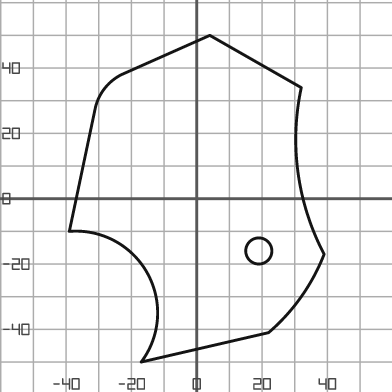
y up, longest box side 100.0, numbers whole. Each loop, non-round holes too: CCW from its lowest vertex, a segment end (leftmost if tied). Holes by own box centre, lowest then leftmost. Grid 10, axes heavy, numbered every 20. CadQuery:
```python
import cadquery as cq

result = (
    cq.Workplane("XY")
    .moveTo(-17.0, -50.0)
    .lineTo(22.0, -41.0)
    .threePointArc((32.0, -30.0), (39.0, -17.0))
    .threePointArc((31.0, 8.0), (32.0, 34.0))
    .lineTo(4.0, 50.0)
    .lineTo(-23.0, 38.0)
    .threePointArc((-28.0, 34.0), (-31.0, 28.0))
    .lineTo(-39.0, -10.0)
    .threePointArc((-15.0, -23.0), (-17.0, -50.0))
    .close()
    .moveTo(19.0, -16.0)
    .circle(4.0)
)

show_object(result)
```